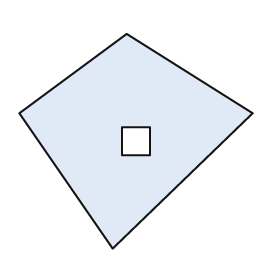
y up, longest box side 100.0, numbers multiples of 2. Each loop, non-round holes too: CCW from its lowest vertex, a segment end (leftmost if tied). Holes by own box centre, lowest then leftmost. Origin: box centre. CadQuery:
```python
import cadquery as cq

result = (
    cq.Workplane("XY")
    .moveTo(-10.0, -46.0)
    .lineTo(50.0, 12.0)
    .lineTo(-4.0, 46.0)
    .lineTo(-50.0, 12.0)
    .close()
    .moveTo(-6.0, -6.0)
    .lineTo(6.0, -6.0)
    .lineTo(6.0, 6.0)
    .lineTo(-6.0, 6.0)
    .close()
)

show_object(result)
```